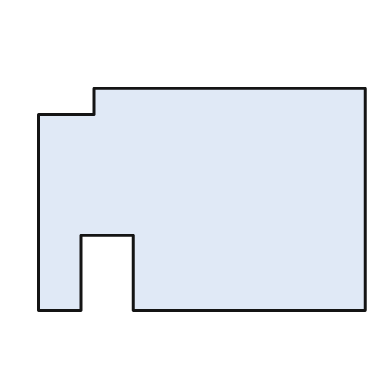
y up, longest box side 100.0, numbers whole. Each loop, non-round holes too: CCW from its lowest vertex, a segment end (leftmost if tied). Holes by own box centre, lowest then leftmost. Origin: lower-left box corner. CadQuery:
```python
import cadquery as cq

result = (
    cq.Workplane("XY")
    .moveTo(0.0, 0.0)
    .lineTo(13.0, 0.0)
    .lineTo(13.0, 23.0)
    .lineTo(29.0, 23.0)
    .lineTo(29.0, 0.0)
    .lineTo(100.0, 0.0)
    .lineTo(100.0, 68.0)
    .lineTo(17.0, 68.0)
    .lineTo(17.0, 60.0)
    .lineTo(0.0, 60.0)
    .close()
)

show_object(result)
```